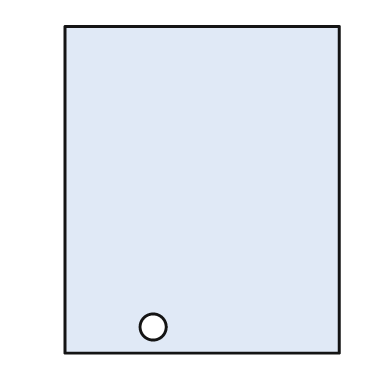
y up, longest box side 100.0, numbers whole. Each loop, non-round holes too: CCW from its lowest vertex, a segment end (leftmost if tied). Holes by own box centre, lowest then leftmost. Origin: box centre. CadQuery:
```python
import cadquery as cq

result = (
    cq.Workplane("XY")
    .moveTo(-42.0, -50.0)
    .lineTo(42.0, -50.0)
    .lineTo(42.0, 50.0)
    .lineTo(-42.0, 50.0)
    .close()
    .moveTo(-15.0, -42.0)
    .circle(4.0)
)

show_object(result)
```